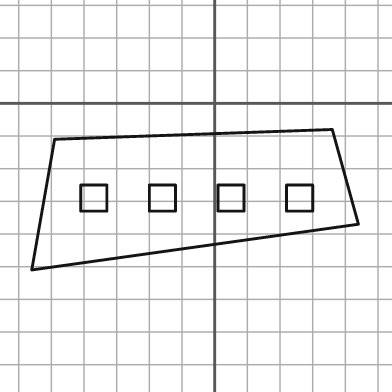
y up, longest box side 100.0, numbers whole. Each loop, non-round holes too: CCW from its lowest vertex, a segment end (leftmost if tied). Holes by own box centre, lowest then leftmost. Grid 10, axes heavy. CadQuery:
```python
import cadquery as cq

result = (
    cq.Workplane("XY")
    .moveTo(-56.0, -51.0)
    .lineTo(44.0, -37.0)
    .lineTo(36.0, -8.0)
    .lineTo(-49.0, -11.0)
    .close()
    .moveTo(-41.0, -33.0)
    .lineTo(-33.0, -33.0)
    .lineTo(-33.0, -25.0)
    .lineTo(-41.0, -25.0)
    .close()
    .moveTo(-20.0, -33.0)
    .lineTo(-12.0, -33.0)
    .lineTo(-12.0, -25.0)
    .lineTo(-20.0, -25.0)
    .close()
    .moveTo(1.0, -33.0)
    .lineTo(9.0, -33.0)
    .lineTo(9.0, -25.0)
    .lineTo(1.0, -25.0)
    .close()
    .moveTo(22.0, -33.0)
    .lineTo(30.0, -33.0)
    .lineTo(30.0, -25.0)
    .lineTo(22.0, -25.0)
    .close()
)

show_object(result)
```